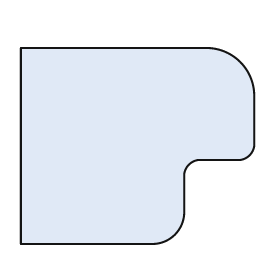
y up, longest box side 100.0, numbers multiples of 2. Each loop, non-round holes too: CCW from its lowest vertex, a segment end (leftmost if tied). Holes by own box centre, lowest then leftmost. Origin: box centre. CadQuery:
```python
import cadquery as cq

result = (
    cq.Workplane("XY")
    .moveTo(-50.0, -42.0)
    .lineTo(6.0, -42.0)
    .threePointArc((16.0, -38.0), (20.0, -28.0))
    .lineTo(20.0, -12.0)
    .threePointArc((22.0, -8.0), (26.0, -6.0))
    .lineTo(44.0, -6.0)
    .threePointArc((48.0, -4.0), (50.0, 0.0))
    .lineTo(50.0, 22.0)
    .threePointArc((44.0, 36.0), (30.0, 42.0))
    .lineTo(-50.0, 42.0)
    .close()
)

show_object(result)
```